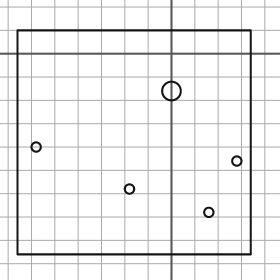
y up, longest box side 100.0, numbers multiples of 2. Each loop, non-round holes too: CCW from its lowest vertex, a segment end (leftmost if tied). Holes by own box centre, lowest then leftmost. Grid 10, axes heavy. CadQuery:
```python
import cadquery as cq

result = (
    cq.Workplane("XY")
    .moveTo(-66.0, -86.0)
    .lineTo(34.0, -86.0)
    .lineTo(34.0, 10.0)
    .lineTo(-66.0, 10.0)
    .close()
    .moveTo(16.0, -68.0)
    .circle(2.0)
    .moveTo(-18.0, -58.0)
    .circle(2.0)
    .moveTo(28.0, -46.0)
    .circle(2.0)
    .moveTo(-58.0, -40.0)
    .circle(2.0)
    .moveTo(0.0, -16.0)
    .circle(4.0)
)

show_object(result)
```